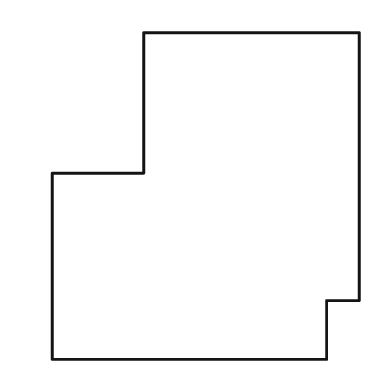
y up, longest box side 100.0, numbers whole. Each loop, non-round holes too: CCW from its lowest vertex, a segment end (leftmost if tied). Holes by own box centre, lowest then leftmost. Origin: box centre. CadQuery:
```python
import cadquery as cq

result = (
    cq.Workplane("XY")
    .moveTo(-47.0, -50.0)
    .lineTo(37.0, -50.0)
    .lineTo(37.0, -32.0)
    .lineTo(47.0, -32.0)
    .lineTo(47.0, 50.0)
    .lineTo(-19.0, 50.0)
    .lineTo(-19.0, 7.0)
    .lineTo(-47.0, 7.0)
    .close()
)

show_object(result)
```